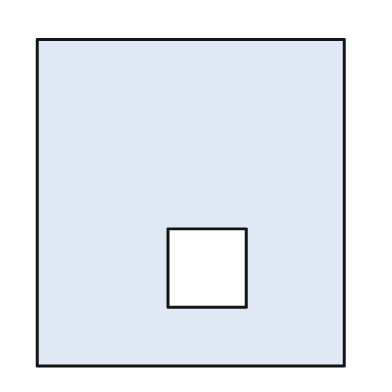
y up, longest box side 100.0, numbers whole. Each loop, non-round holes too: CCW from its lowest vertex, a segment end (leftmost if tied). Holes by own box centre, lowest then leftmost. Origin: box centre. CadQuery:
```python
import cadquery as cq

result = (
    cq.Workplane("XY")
    .moveTo(-47.0, -50.0)
    .lineTo(47.0, -50.0)
    .lineTo(47.0, 50.0)
    .lineTo(-47.0, 50.0)
    .close()
    .moveTo(-7.0, -32.0)
    .lineTo(17.0, -32.0)
    .lineTo(17.0, -8.0)
    .lineTo(-7.0, -8.0)
    .close()
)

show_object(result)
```